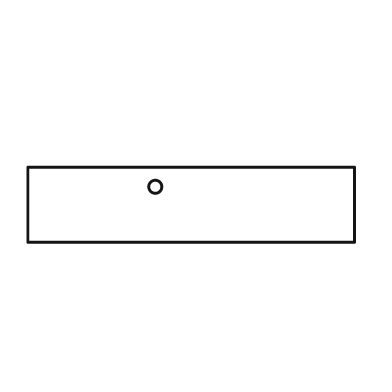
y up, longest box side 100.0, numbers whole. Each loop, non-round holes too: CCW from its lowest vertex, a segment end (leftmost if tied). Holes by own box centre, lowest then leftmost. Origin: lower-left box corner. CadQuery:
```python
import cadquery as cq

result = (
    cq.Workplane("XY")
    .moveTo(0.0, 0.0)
    .lineTo(100.0, 0.0)
    .lineTo(100.0, 23.0)
    .lineTo(0.0, 23.0)
    .close()
    .moveTo(39.0, 17.0)
    .circle(2.0)
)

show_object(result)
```